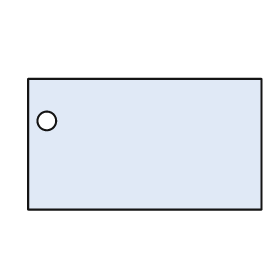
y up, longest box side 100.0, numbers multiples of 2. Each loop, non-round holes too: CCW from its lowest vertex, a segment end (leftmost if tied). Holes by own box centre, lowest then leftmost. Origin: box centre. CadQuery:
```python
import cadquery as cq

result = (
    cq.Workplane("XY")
    .moveTo(-50.0, -28.0)
    .lineTo(50.0, -28.0)
    .lineTo(50.0, 28.0)
    .lineTo(-50.0, 28.0)
    .close()
    .moveTo(-42.0, 10.0)
    .circle(4.0)
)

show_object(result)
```